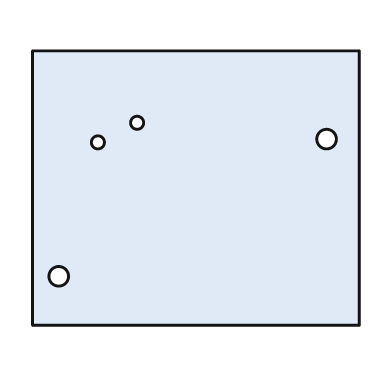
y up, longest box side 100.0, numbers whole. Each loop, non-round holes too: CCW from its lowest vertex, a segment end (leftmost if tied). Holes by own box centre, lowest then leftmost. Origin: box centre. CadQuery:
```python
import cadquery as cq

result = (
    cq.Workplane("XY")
    .moveTo(-50.0, -42.0)
    .lineTo(50.0, -42.0)
    .lineTo(50.0, 42.0)
    .lineTo(-50.0, 42.0)
    .close()
    .moveTo(-42.0, -27.0)
    .circle(3.0)
    .moveTo(-30.0, 14.0)
    .circle(2.0)
    .moveTo(40.0, 15.0)
    .circle(3.0)
    .moveTo(-18.0, 20.0)
    .circle(2.0)
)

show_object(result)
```